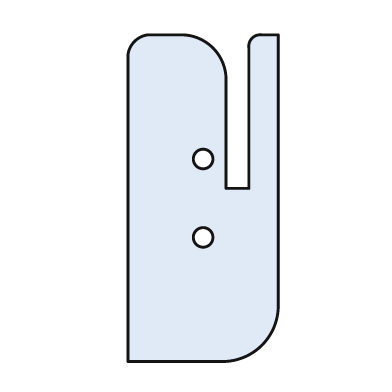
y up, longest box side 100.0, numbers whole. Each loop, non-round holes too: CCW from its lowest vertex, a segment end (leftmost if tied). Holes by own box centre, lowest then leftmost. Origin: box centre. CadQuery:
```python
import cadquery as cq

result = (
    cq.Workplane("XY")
    .moveTo(-23.0, -50.0)
    .lineTo(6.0, -50.0)
    .threePointArc((18.0, -45.0), (23.0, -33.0))
    .lineTo(23.0, 50.0)
    .lineTo(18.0, 50.0)
    .threePointArc((15.0, 49.0), (14.0, 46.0))
    .lineTo(14.0, 3.0)
    .lineTo(7.0, 3.0)
    .lineTo(7.0, 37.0)
    .threePointArc((3.0, 46.0), (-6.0, 50.0))
    .lineTo(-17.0, 50.0)
    .threePointArc((-21.0, 48.0), (-23.0, 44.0))
    .close()
    .moveTo(0.0, -12.0)
    .circle(3.0)
    .moveTo(0.0, 12.0)
    .circle(3.0)
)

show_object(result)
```